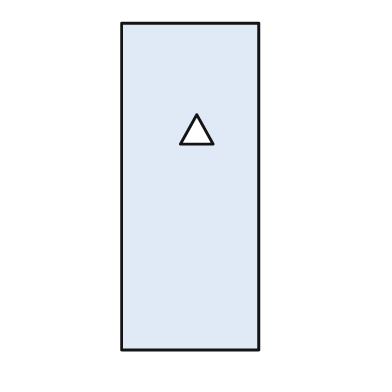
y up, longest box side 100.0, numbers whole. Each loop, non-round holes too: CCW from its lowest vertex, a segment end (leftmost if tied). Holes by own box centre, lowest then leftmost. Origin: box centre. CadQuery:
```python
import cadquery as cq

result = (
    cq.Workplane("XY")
    .moveTo(-21.0, -50.0)
    .lineTo(21.0, -50.0)
    .lineTo(21.0, 50.0)
    .lineTo(-21.0, 50.0)
    .close()
    .moveTo(-3.0, 13.0)
    .lineTo(7.0, 13.0)
    .lineTo(2.0, 22.0)
    .close()
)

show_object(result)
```